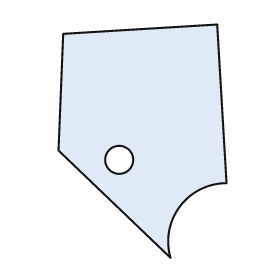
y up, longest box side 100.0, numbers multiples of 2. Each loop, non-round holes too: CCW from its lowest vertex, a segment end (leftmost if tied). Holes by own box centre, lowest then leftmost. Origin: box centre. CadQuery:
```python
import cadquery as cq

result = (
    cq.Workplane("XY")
    .moveTo(12.0, -50.0)
    .threePointArc((16.0, -28.0), (36.0, -18.0))
    .lineTo(32.0, 50.0)
    .lineTo(-34.0, 46.0)
    .lineTo(-36.0, -4.0)
    .close()
    .moveTo(-10.0, -8.0)
    .circle(6.0)
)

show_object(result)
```